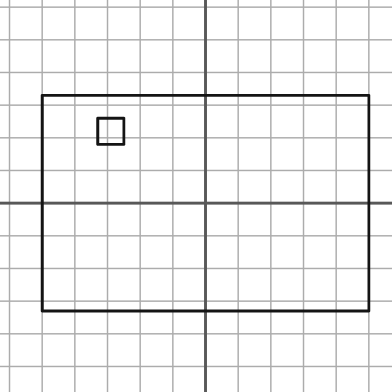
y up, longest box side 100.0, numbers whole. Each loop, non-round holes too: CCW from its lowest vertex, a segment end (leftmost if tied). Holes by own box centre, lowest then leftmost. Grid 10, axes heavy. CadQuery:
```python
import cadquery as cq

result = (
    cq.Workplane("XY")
    .moveTo(-50.0, -33.0)
    .lineTo(50.0, -33.0)
    .lineTo(50.0, 33.0)
    .lineTo(-50.0, 33.0)
    .close()
    .moveTo(-33.0, 18.0)
    .lineTo(-25.0, 18.0)
    .lineTo(-25.0, 26.0)
    .lineTo(-33.0, 26.0)
    .close()
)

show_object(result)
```